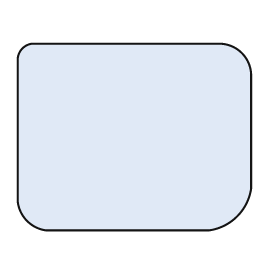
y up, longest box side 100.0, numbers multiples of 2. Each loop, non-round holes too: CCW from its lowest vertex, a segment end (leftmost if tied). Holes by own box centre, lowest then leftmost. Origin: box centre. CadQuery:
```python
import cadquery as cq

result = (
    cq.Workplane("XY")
    .moveTo(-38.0, -40.0)
    .lineTo(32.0, -40.0)
    .threePointArc((44.0, -34.0), (50.0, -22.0))
    .lineTo(50.0, 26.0)
    .threePointArc((46.0, 36.0), (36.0, 40.0))
    .lineTo(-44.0, 40.0)
    .threePointArc((-48.0, 38.0), (-50.0, 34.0))
    .lineTo(-50.0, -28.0)
    .threePointArc((-46.0, -36.0), (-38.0, -40.0))
    .close()
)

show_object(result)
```